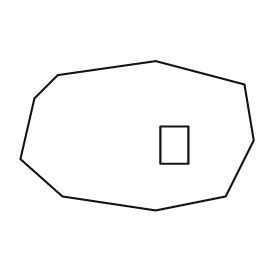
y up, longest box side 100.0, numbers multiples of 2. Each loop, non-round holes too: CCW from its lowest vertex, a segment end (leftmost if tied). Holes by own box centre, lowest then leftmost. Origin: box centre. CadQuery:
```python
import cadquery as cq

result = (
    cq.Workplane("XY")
    .moveTo(8.0, -32.0)
    .lineTo(38.0, -26.0)
    .lineTo(50.0, -2.0)
    .lineTo(46.0, 22.0)
    .lineTo(8.0, 32.0)
    .lineTo(-34.0, 26.0)
    .lineTo(-44.0, 16.0)
    .lineTo(-50.0, -10.0)
    .lineTo(-32.0, -26.0)
    .close()
    .moveTo(10.0, -12.0)
    .lineTo(22.0, -12.0)
    .lineTo(22.0, 4.0)
    .lineTo(10.0, 4.0)
    .close()
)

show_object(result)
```